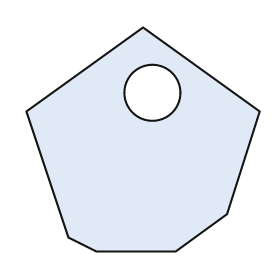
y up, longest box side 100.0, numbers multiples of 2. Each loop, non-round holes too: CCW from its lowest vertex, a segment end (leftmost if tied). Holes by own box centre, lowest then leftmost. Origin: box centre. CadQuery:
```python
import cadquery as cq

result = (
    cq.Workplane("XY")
    .moveTo(-20.0, -48.0)
    .lineTo(14.0, -48.0)
    .lineTo(36.0, -32.0)
    .lineTo(50.0, 12.0)
    .lineTo(0.0, 48.0)
    .lineTo(-50.0, 12.0)
    .lineTo(-32.0, -42.0)
    .close()
    .moveTo(4.0, 20.0)
    .circle(12.0)
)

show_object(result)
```